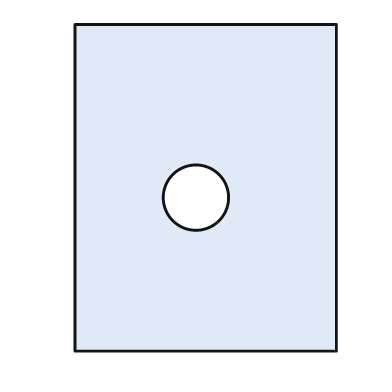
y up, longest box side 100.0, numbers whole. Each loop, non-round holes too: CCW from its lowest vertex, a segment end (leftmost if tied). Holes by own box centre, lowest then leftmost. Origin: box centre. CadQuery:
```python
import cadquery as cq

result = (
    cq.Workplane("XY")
    .moveTo(-40.0, -50.0)
    .lineTo(40.0, -50.0)
    .lineTo(40.0, 50.0)
    .lineTo(-40.0, 50.0)
    .close()
    .moveTo(-3.0, -3.0)
    .circle(10.0)
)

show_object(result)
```